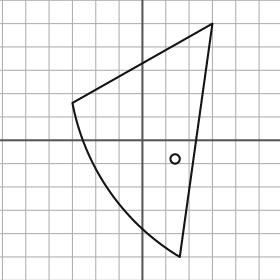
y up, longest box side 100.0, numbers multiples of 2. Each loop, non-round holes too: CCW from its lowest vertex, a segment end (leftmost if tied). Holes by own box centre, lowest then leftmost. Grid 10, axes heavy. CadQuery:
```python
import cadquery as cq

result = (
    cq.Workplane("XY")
    .moveTo(16.0, -50.0)
    .lineTo(30.0, 50.0)
    .lineTo(-30.0, 16.0)
    .threePointArc((-14.0, -22.0), (16.0, -50.0))
    .close()
    .moveTo(14.0, -8.0)
    .circle(2.0)
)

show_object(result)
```